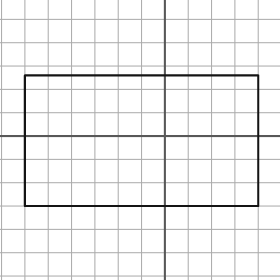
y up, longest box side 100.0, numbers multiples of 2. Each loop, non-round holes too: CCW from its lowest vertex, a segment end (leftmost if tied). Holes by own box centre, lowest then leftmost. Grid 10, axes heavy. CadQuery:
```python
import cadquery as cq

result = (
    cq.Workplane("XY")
    .moveTo(-60.0, -30.0)
    .lineTo(40.0, -30.0)
    .lineTo(40.0, 26.0)
    .lineTo(-60.0, 26.0)
    .close()
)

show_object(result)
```